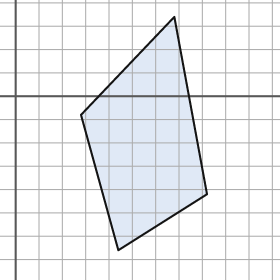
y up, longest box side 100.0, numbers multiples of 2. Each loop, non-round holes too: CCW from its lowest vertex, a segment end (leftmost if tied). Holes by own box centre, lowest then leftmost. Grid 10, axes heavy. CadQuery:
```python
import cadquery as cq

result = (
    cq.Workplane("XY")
    .moveTo(44.0, -66.0)
    .lineTo(82.0, -42.0)
    .lineTo(68.0, 34.0)
    .lineTo(28.0, -8.0)
    .close()
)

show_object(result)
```